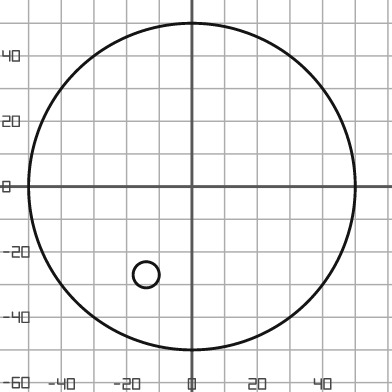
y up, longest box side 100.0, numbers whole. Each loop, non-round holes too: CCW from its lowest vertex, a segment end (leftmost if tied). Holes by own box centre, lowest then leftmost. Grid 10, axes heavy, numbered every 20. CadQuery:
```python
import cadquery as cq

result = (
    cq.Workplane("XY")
    .moveTo(0.0, 0.0)
    .circle(50.0)
    .moveTo(-14.0, -27.0)
    .circle(4.0)
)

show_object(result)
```